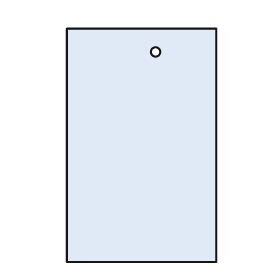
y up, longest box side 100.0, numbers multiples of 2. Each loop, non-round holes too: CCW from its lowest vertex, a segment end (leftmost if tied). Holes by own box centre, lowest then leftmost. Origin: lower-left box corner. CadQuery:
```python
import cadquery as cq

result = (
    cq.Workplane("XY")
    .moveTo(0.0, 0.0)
    .lineTo(64.0, 0.0)
    .lineTo(64.0, 100.0)
    .lineTo(0.0, 100.0)
    .close()
    .moveTo(38.0, 90.0)
    .circle(2.0)
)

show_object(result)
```